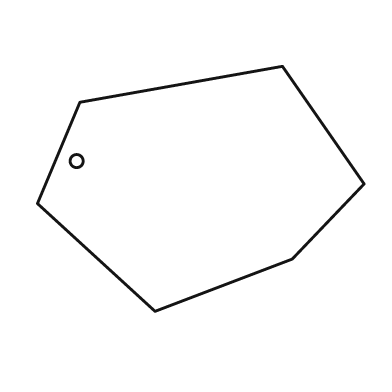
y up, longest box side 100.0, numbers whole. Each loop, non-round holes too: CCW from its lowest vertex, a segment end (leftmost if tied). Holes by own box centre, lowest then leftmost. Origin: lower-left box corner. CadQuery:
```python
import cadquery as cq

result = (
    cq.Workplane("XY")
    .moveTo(36.0, 0.0)
    .lineTo(78.0, 16.0)
    .lineTo(100.0, 39.0)
    .lineTo(75.0, 75.0)
    .lineTo(13.0, 64.0)
    .lineTo(0.0, 33.0)
    .close()
    .moveTo(12.0, 46.0)
    .circle(2.0)
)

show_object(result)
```